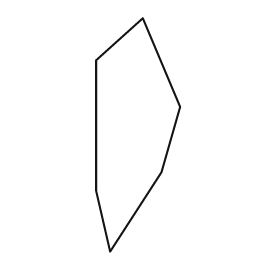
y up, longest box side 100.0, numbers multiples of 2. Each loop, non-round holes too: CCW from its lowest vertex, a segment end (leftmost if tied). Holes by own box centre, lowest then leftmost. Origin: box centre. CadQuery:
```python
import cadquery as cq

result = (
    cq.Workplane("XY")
    .moveTo(-12.0, -50.0)
    .lineTo(10.0, -16.0)
    .lineTo(18.0, 12.0)
    .lineTo(2.0, 50.0)
    .lineTo(-18.0, 32.0)
    .lineTo(-18.0, -24.0)
    .close()
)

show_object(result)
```